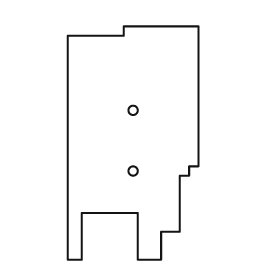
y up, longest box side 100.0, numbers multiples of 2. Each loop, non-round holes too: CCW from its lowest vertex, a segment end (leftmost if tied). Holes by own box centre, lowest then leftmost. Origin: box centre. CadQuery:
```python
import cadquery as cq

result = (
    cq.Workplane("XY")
    .moveTo(-28.0, -50.0)
    .lineTo(-22.0, -50.0)
    .lineTo(-22.0, -30.0)
    .lineTo(2.0, -30.0)
    .lineTo(2.0, -50.0)
    .lineTo(12.0, -50.0)
    .lineTo(12.0, -38.0)
    .lineTo(20.0, -38.0)
    .lineTo(20.0, -14.0)
    .lineTo(24.0, -14.0)
    .lineTo(24.0, -10.0)
    .lineTo(28.0, -10.0)
    .lineTo(28.0, 50.0)
    .lineTo(-4.0, 50.0)
    .lineTo(-4.0, 46.0)
    .lineTo(-28.0, 46.0)
    .close()
    .moveTo(0.0, -12.0)
    .circle(2.0)
    .moveTo(0.0, 14.0)
    .circle(2.0)
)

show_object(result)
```